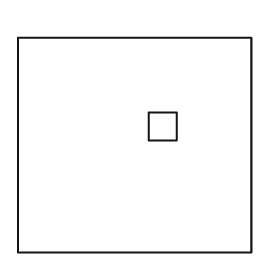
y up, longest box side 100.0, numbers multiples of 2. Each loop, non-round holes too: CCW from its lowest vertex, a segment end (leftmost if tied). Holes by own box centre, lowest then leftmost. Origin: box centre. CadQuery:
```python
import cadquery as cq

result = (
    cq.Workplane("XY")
    .moveTo(-50.0, -46.0)
    .lineTo(50.0, -46.0)
    .lineTo(50.0, 46.0)
    .lineTo(-50.0, 46.0)
    .close()
    .moveTo(6.0, 2.0)
    .lineTo(18.0, 2.0)
    .lineTo(18.0, 14.0)
    .lineTo(6.0, 14.0)
    .close()
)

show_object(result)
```